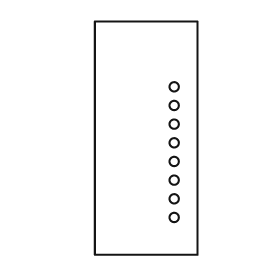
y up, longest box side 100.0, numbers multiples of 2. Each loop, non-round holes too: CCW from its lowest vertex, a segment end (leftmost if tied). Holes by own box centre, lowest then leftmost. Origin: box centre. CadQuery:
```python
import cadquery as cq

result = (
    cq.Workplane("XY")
    .moveTo(-22.0, -50.0)
    .lineTo(22.0, -50.0)
    .lineTo(22.0, 50.0)
    .lineTo(-22.0, 50.0)
    .close()
    .moveTo(12.0, -34.0)
    .circle(2.0)
    .moveTo(12.0, -26.0)
    .circle(2.0)
    .moveTo(12.0, -18.0)
    .circle(2.0)
    .moveTo(12.0, -10.0)
    .circle(2.0)
    .moveTo(12.0, -2.0)
    .circle(2.0)
    .moveTo(12.0, 6.0)
    .circle(2.0)
    .moveTo(12.0, 14.0)
    .circle(2.0)
    .moveTo(12.0, 22.0)
    .circle(2.0)
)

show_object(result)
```